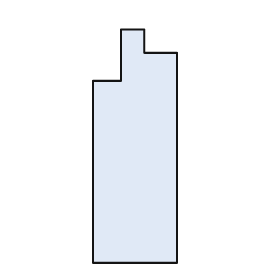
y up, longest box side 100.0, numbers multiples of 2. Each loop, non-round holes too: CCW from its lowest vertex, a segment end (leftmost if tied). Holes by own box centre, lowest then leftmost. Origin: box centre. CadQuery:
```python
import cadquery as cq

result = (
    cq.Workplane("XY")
    .moveTo(-18.0, -50.0)
    .lineTo(18.0, -50.0)
    .lineTo(18.0, 40.0)
    .lineTo(4.0, 40.0)
    .lineTo(4.0, 50.0)
    .lineTo(-6.0, 50.0)
    .lineTo(-6.0, 28.0)
    .lineTo(-18.0, 28.0)
    .close()
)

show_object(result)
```